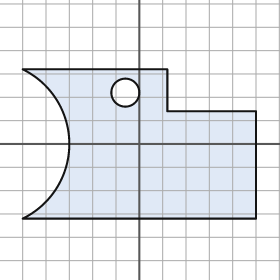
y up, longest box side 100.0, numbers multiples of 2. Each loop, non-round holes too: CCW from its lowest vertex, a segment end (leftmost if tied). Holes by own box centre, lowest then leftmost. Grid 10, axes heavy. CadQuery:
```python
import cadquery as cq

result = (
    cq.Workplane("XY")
    .moveTo(-50.0, -32.0)
    .lineTo(50.0, -32.0)
    .lineTo(50.0, 14.0)
    .lineTo(12.0, 14.0)
    .lineTo(12.0, 32.0)
    .lineTo(-50.0, 32.0)
    .threePointArc((-30.0, 0.0), (-50.0, -32.0))
    .close()
    .moveTo(-6.0, 22.0)
    .circle(6.0)
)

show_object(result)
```